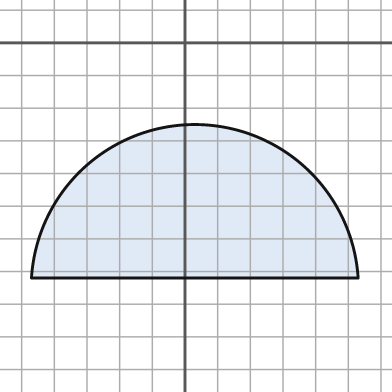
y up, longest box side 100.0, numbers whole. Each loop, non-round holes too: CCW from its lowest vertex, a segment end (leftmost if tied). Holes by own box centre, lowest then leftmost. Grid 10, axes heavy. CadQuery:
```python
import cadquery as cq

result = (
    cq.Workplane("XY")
    .moveTo(-47.0, -72.0)
    .lineTo(53.0, -72.0)
    .threePointArc((3.0, -25.0), (-47.0, -72.0))
    .close()
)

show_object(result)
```